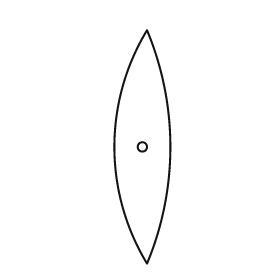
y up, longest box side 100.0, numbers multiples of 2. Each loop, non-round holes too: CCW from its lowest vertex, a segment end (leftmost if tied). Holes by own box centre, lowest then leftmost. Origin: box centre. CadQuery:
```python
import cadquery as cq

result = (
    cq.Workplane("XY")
    .moveTo(2.0, -50.0)
    .threePointArc((12.0, 0.0), (2.0, 50.0))
    .threePointArc((-12.0, 0.0), (2.0, -50.0))
    .close()
    .moveTo(0.0, 0.0)
    .circle(2.0)
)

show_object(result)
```